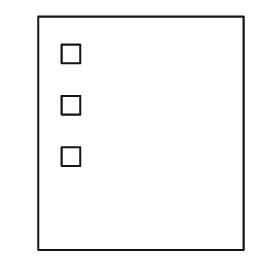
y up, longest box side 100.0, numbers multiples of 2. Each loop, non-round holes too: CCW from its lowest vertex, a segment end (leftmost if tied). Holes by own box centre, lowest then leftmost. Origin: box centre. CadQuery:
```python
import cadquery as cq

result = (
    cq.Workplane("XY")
    .moveTo(-44.0, -50.0)
    .lineTo(44.0, -50.0)
    .lineTo(44.0, 50.0)
    .lineTo(-44.0, 50.0)
    .close()
    .moveTo(-34.0, -14.0)
    .lineTo(-26.0, -14.0)
    .lineTo(-26.0, -6.0)
    .lineTo(-34.0, -6.0)
    .close()
    .moveTo(-34.0, 8.0)
    .lineTo(-26.0, 8.0)
    .lineTo(-26.0, 16.0)
    .lineTo(-34.0, 16.0)
    .close()
    .moveTo(-34.0, 30.0)
    .lineTo(-26.0, 30.0)
    .lineTo(-26.0, 38.0)
    .lineTo(-34.0, 38.0)
    .close()
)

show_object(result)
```